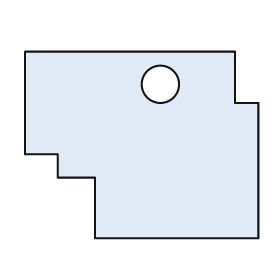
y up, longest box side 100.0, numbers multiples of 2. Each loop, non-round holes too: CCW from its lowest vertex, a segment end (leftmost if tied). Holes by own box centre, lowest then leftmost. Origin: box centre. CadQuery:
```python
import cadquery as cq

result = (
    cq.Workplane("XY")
    .moveTo(-20.0, -40.0)
    .lineTo(50.0, -40.0)
    .lineTo(50.0, 18.0)
    .lineTo(40.0, 18.0)
    .lineTo(40.0, 40.0)
    .lineTo(-50.0, 40.0)
    .lineTo(-50.0, -4.0)
    .lineTo(-36.0, -4.0)
    .lineTo(-36.0, -14.0)
    .lineTo(-20.0, -14.0)
    .close()
    .moveTo(8.0, 26.0)
    .circle(8.0)
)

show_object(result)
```